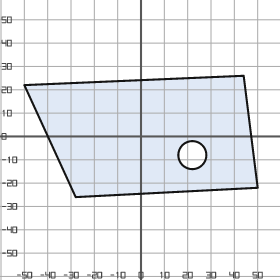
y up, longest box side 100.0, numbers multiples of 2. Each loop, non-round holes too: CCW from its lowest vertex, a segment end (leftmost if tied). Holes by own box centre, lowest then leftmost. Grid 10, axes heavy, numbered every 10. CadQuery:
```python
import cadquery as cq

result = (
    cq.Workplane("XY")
    .moveTo(-28.0, -26.0)
    .lineTo(50.0, -22.0)
    .lineTo(44.0, 26.0)
    .lineTo(-50.0, 22.0)
    .close()
    .moveTo(22.0, -8.0)
    .circle(6.0)
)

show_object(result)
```